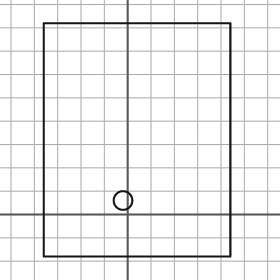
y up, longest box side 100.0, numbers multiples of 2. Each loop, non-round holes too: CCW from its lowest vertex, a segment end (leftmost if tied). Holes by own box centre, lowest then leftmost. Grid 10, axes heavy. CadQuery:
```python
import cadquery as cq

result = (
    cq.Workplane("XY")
    .moveTo(-36.0, -18.0)
    .lineTo(44.0, -18.0)
    .lineTo(44.0, 82.0)
    .lineTo(-36.0, 82.0)
    .close()
    .moveTo(-2.0, 6.0)
    .circle(4.0)
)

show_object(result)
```